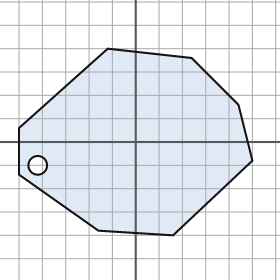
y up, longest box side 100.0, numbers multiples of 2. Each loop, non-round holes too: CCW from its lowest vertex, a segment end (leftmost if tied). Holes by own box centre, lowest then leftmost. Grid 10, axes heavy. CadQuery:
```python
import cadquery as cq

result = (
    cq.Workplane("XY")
    .moveTo(16.0, -40.0)
    .lineTo(50.0, -8.0)
    .lineTo(44.0, 16.0)
    .lineTo(24.0, 36.0)
    .lineTo(-12.0, 40.0)
    .lineTo(-50.0, 6.0)
    .lineTo(-50.0, -14.0)
    .lineTo(-16.0, -38.0)
    .close()
    .moveTo(-42.0, -10.0)
    .circle(4.0)
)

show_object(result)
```